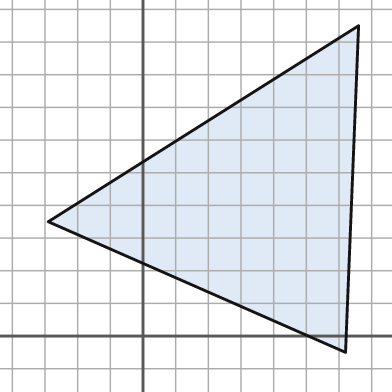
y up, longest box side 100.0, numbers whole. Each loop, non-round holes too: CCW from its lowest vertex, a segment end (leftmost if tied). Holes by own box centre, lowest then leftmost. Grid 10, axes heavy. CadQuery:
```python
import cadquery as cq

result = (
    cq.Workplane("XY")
    .moveTo(62.0, -5.0)
    .lineTo(66.0, 95.0)
    .lineTo(-29.0, 35.0)
    .close()
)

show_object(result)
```